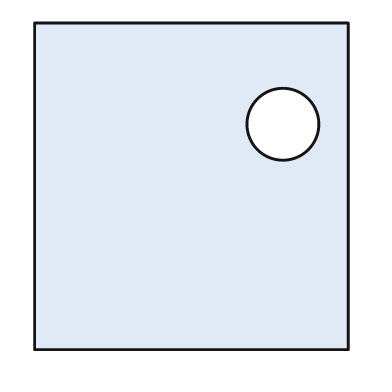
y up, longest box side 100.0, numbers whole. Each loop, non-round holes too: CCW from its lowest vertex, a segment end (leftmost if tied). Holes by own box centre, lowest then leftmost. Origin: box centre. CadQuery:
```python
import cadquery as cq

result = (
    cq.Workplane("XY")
    .moveTo(-48.0, -50.0)
    .lineTo(48.0, -50.0)
    .lineTo(48.0, 50.0)
    .lineTo(-48.0, 50.0)
    .close()
    .moveTo(28.0, 19.0)
    .circle(11.0)
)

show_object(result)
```